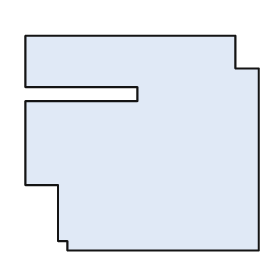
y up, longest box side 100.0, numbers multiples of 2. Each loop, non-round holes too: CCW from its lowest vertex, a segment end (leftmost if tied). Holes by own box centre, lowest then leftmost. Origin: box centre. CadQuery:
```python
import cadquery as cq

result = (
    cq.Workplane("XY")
    .moveTo(-32.0, -46.0)
    .lineTo(50.0, -46.0)
    .lineTo(50.0, 32.0)
    .lineTo(40.0, 32.0)
    .lineTo(40.0, 46.0)
    .lineTo(-50.0, 46.0)
    .lineTo(-50.0, 24.0)
    .lineTo(-2.0, 24.0)
    .lineTo(-2.0, 18.0)
    .lineTo(-50.0, 18.0)
    .lineTo(-50.0, -18.0)
    .lineTo(-36.0, -18.0)
    .lineTo(-36.0, -42.0)
    .lineTo(-32.0, -42.0)
    .close()
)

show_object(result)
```